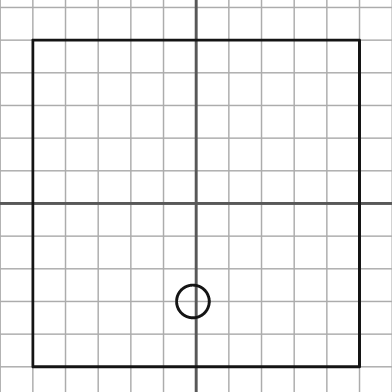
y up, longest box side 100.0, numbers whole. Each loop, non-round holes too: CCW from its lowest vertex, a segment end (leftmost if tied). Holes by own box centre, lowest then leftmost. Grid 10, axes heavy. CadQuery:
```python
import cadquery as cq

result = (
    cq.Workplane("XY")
    .moveTo(-50.0, -50.0)
    .lineTo(50.0, -50.0)
    .lineTo(50.0, 50.0)
    .lineTo(-50.0, 50.0)
    .close()
    .moveTo(-1.0, -30.0)
    .circle(5.0)
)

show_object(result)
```